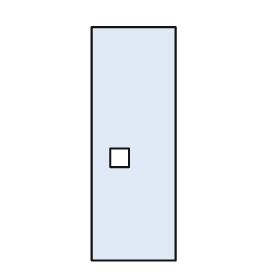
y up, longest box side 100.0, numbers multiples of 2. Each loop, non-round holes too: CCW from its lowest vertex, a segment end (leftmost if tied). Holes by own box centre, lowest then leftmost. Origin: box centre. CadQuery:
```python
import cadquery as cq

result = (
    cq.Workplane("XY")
    .moveTo(-18.0, -50.0)
    .lineTo(18.0, -50.0)
    .lineTo(18.0, 50.0)
    .lineTo(-18.0, 50.0)
    .close()
    .moveTo(-10.0, -10.0)
    .lineTo(-2.0, -10.0)
    .lineTo(-2.0, -2.0)
    .lineTo(-10.0, -2.0)
    .close()
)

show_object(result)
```